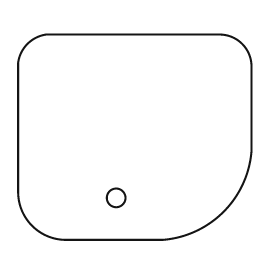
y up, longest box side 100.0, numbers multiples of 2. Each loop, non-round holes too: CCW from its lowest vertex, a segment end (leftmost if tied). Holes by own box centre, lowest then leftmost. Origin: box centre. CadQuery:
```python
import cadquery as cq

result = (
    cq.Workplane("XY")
    .moveTo(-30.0, -44.0)
    .lineTo(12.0, -44.0)
    .threePointArc((38.0, -32.0), (50.0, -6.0))
    .lineTo(50.0, 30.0)
    .threePointArc((46.0, 40.0), (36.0, 44.0))
    .lineTo(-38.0, 44.0)
    .threePointArc((-46.0, 40.0), (-50.0, 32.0))
    .lineTo(-50.0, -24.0)
    .threePointArc((-44.0, -38.0), (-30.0, -44.0))
    .close()
    .moveTo(-8.0, -26.0)
    .circle(4.0)
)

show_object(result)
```